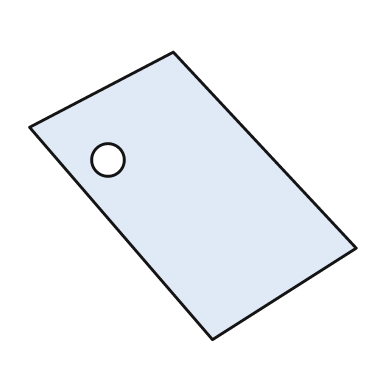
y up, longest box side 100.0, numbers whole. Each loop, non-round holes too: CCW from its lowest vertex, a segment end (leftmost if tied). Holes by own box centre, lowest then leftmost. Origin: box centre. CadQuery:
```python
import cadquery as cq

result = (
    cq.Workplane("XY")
    .moveTo(6.0, -44.0)
    .lineTo(50.0, -16.0)
    .lineTo(-6.0, 44.0)
    .lineTo(-50.0, 21.0)
    .close()
    .moveTo(-26.0, 11.0)
    .circle(5.0)
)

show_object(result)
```